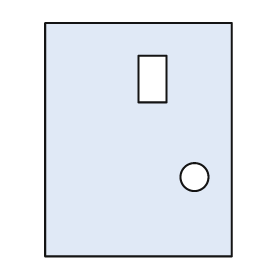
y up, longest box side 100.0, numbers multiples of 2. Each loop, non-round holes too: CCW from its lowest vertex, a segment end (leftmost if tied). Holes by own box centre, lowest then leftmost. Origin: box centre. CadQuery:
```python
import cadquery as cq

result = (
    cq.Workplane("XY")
    .moveTo(-40.0, -50.0)
    .lineTo(40.0, -50.0)
    .lineTo(40.0, 50.0)
    .lineTo(-40.0, 50.0)
    .close()
    .moveTo(24.0, -16.0)
    .circle(6.0)
    .moveTo(0.0, 16.0)
    .lineTo(12.0, 16.0)
    .lineTo(12.0, 36.0)
    .lineTo(0.0, 36.0)
    .close()
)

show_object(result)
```